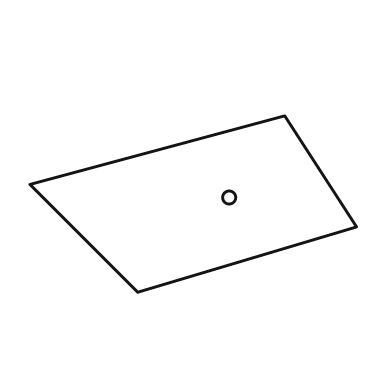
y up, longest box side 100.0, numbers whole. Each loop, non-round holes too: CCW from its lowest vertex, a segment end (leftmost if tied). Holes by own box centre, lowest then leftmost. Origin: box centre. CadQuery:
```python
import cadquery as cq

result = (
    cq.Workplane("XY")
    .moveTo(-17.0, -27.0)
    .lineTo(50.0, -7.0)
    .lineTo(28.0, 27.0)
    .lineTo(-50.0, 6.0)
    .close()
    .moveTo(11.0, 2.0)
    .circle(2.0)
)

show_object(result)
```